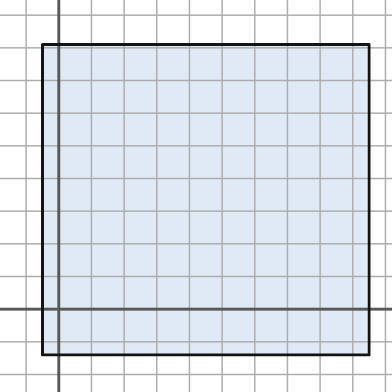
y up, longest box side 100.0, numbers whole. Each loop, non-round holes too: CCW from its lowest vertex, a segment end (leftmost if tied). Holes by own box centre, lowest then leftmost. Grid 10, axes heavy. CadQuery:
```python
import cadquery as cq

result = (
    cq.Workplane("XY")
    .moveTo(-5.0, -14.0)
    .lineTo(95.0, -14.0)
    .lineTo(95.0, 81.0)
    .lineTo(-5.0, 81.0)
    .close()
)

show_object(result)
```